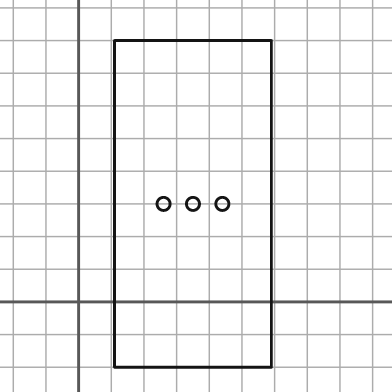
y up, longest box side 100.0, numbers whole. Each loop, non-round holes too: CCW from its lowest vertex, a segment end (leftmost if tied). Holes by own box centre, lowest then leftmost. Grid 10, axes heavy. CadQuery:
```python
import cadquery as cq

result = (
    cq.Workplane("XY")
    .moveTo(11.0, -20.0)
    .lineTo(59.0, -20.0)
    .lineTo(59.0, 80.0)
    .lineTo(11.0, 80.0)
    .close()
    .moveTo(26.0, 30.0)
    .circle(2.0)
    .moveTo(35.0, 30.0)
    .circle(2.0)
    .moveTo(44.0, 30.0)
    .circle(2.0)
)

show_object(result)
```